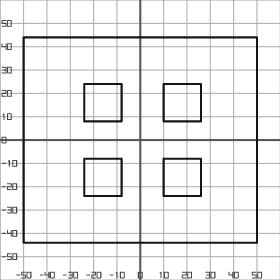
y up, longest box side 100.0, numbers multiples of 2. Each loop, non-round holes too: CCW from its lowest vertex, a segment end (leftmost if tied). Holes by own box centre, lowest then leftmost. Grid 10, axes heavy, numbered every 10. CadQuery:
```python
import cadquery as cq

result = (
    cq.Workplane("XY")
    .moveTo(-50.0, -44.0)
    .lineTo(50.0, -44.0)
    .lineTo(50.0, 44.0)
    .lineTo(-50.0, 44.0)
    .close()
    .moveTo(-24.0, -24.0)
    .lineTo(-8.0, -24.0)
    .lineTo(-8.0, -8.0)
    .lineTo(-24.0, -8.0)
    .close()
    .moveTo(10.0, -24.0)
    .lineTo(26.0, -24.0)
    .lineTo(26.0, -8.0)
    .lineTo(10.0, -8.0)
    .close()
    .moveTo(-24.0, 8.0)
    .lineTo(-8.0, 8.0)
    .lineTo(-8.0, 24.0)
    .lineTo(-24.0, 24.0)
    .close()
    .moveTo(10.0, 8.0)
    .lineTo(26.0, 8.0)
    .lineTo(26.0, 24.0)
    .lineTo(10.0, 24.0)
    .close()
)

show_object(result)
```